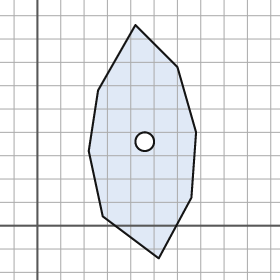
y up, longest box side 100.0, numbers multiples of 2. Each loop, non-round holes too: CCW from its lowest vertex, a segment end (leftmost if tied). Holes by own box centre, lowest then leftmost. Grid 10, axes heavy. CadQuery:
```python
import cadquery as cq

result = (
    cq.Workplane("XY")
    .moveTo(52.0, -14.0)
    .lineTo(66.0, 12.0)
    .lineTo(68.0, 40.0)
    .lineTo(60.0, 68.0)
    .lineTo(42.0, 86.0)
    .lineTo(26.0, 58.0)
    .lineTo(22.0, 32.0)
    .lineTo(28.0, 4.0)
    .close()
    .moveTo(46.0, 36.0)
    .circle(4.0)
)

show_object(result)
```